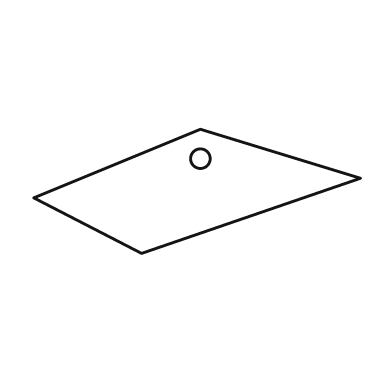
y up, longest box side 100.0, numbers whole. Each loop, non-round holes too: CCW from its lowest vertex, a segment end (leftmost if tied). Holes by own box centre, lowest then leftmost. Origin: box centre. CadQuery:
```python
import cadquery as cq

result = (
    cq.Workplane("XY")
    .moveTo(-17.0, -19.0)
    .lineTo(50.0, 4.0)
    .lineTo(1.0, 19.0)
    .lineTo(-50.0, -2.0)
    .close()
    .moveTo(1.0, 10.0)
    .circle(3.0)
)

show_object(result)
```